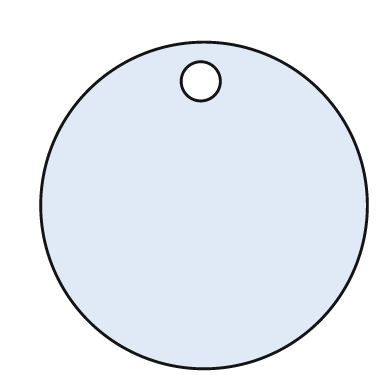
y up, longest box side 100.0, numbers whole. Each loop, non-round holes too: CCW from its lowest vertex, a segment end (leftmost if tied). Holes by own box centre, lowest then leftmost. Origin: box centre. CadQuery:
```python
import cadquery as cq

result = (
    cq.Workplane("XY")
    .moveTo(0.0, 0.0)
    .circle(50.0)
    .moveTo(-1.0, 38.0)
    .circle(6.0)
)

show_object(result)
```